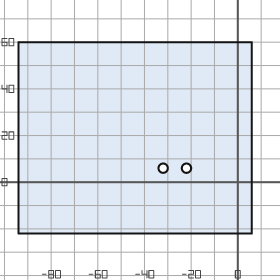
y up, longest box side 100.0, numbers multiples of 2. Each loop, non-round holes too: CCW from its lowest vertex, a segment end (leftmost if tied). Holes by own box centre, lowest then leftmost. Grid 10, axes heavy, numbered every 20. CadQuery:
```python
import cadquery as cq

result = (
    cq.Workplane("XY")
    .moveTo(-94.0, -22.0)
    .lineTo(6.0, -22.0)
    .lineTo(6.0, 60.0)
    .lineTo(-94.0, 60.0)
    .close()
    .moveTo(-32.0, 6.0)
    .circle(2.0)
    .moveTo(-22.0, 6.0)
    .circle(2.0)
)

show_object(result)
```